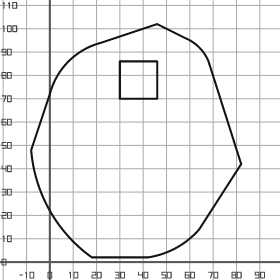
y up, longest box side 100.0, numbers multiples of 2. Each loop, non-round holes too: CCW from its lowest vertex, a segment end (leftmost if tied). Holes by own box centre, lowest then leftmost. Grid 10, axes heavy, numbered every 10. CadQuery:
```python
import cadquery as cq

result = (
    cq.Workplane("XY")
    .moveTo(18.0, 2.0)
    .lineTo(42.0, 2.0)
    .threePointArc((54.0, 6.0), (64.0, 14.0))
    .lineTo(82.0, 42.0)
    .lineTo(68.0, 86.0)
    .threePointArc((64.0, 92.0), (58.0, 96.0))
    .lineTo(46.0, 102.0)
    .lineTo(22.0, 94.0)
    .threePointArc((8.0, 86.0), (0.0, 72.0))
    .lineTo(-8.0, 48.0)
    .threePointArc((0.0, 22.0), (18.0, 2.0))
    .close()
    .moveTo(30.0, 70.0)
    .lineTo(46.0, 70.0)
    .lineTo(46.0, 86.0)
    .lineTo(30.0, 86.0)
    .close()
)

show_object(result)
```